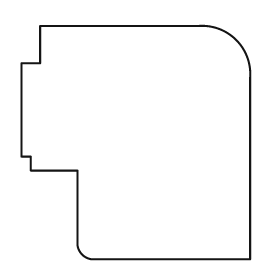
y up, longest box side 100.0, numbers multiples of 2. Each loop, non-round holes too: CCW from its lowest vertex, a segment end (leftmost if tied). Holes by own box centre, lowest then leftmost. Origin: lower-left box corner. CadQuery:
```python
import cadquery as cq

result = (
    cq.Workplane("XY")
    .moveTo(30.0, 0.0)
    .lineTo(98.0, 0.0)
    .lineTo(98.0, 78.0)
    .threePointArc((92.0, 94.0), (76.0, 100.0))
    .lineTo(8.0, 100.0)
    .lineTo(8.0, 84.0)
    .lineTo(0.0, 84.0)
    .lineTo(0.0, 44.0)
    .lineTo(4.0, 44.0)
    .lineTo(4.0, 38.0)
    .lineTo(24.0, 38.0)
    .lineTo(24.0, 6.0)
    .threePointArc((26.0, 2.0), (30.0, 0.0))
    .close()
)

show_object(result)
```